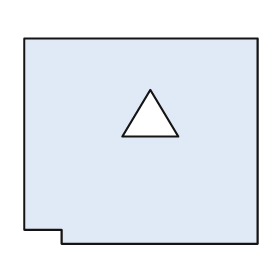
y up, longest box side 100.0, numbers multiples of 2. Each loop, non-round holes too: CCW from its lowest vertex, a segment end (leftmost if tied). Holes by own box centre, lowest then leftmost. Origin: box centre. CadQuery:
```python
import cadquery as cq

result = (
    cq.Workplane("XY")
    .moveTo(-34.0, -44.0)
    .lineTo(50.0, -44.0)
    .lineTo(50.0, 44.0)
    .lineTo(-50.0, 44.0)
    .lineTo(-50.0, -38.0)
    .lineTo(-34.0, -38.0)
    .close()
    .moveTo(-8.0, 2.0)
    .lineTo(16.0, 2.0)
    .lineTo(4.0, 22.0)
    .close()
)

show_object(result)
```